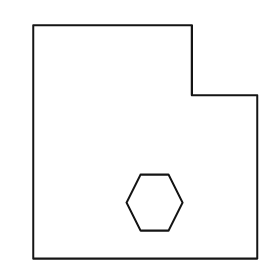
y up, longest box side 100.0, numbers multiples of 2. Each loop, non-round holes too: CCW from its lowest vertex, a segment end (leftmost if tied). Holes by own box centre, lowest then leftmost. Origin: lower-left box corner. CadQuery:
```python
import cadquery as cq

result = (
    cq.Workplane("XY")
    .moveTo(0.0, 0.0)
    .lineTo(96.0, 0.0)
    .lineTo(96.0, 70.0)
    .lineTo(68.0, 70.0)
    .lineTo(68.0, 100.0)
    .lineTo(0.0, 100.0)
    .close()
    .moveTo(46.0, 12.0)
    .lineTo(58.0, 12.0)
    .lineTo(64.0, 24.0)
    .lineTo(58.0, 36.0)
    .lineTo(46.0, 36.0)
    .lineTo(40.0, 24.0)
    .close()
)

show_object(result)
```